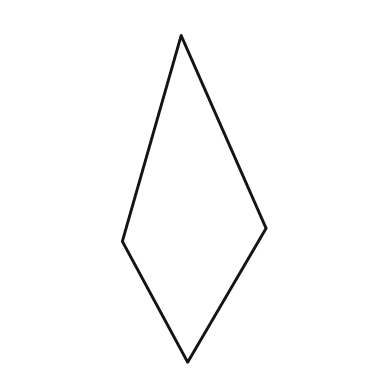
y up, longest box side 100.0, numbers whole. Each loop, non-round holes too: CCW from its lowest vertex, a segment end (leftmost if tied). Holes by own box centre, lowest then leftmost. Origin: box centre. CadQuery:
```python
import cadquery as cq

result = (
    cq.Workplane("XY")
    .moveTo(-2.0, -50.0)
    .lineTo(22.0, -9.0)
    .lineTo(-4.0, 50.0)
    .lineTo(-22.0, -13.0)
    .close()
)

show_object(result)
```